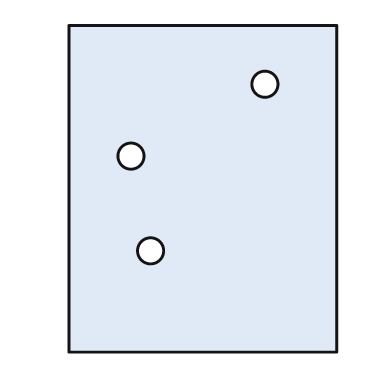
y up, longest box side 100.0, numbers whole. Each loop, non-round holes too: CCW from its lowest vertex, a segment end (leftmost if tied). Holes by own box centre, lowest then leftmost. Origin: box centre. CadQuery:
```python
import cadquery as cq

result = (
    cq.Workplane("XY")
    .moveTo(-41.0, -50.0)
    .lineTo(41.0, -50.0)
    .lineTo(41.0, 50.0)
    .lineTo(-41.0, 50.0)
    .close()
    .moveTo(-16.0, -19.0)
    .circle(4.0)
    .moveTo(-22.0, 10.0)
    .circle(4.0)
    .moveTo(19.0, 32.0)
    .circle(4.0)
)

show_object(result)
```